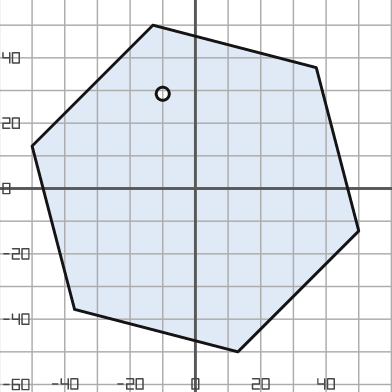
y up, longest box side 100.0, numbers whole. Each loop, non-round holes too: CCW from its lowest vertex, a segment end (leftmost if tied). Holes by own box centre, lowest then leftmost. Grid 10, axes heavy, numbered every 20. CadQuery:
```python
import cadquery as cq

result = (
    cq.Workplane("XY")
    .moveTo(13.0, -50.0)
    .lineTo(50.0, -13.0)
    .lineTo(37.0, 37.0)
    .lineTo(-13.0, 50.0)
    .lineTo(-50.0, 13.0)
    .lineTo(-37.0, -37.0)
    .close()
    .moveTo(-10.0, 29.0)
    .circle(2.0)
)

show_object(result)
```